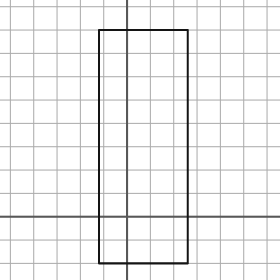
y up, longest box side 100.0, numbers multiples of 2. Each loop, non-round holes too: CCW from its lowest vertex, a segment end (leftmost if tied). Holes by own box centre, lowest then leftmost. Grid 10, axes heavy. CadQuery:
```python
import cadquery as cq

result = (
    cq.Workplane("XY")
    .moveTo(-12.0, -20.0)
    .lineTo(26.0, -20.0)
    .lineTo(26.0, 80.0)
    .lineTo(-12.0, 80.0)
    .close()
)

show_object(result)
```